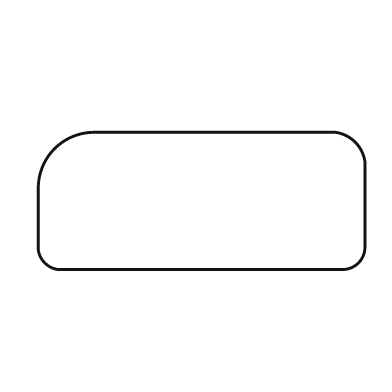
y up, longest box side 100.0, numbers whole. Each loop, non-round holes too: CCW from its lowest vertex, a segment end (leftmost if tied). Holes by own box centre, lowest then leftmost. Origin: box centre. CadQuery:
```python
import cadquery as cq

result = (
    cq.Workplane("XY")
    .moveTo(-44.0, -21.0)
    .lineTo(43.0, -21.0)
    .threePointArc((48.0, -19.0), (50.0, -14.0))
    .lineTo(50.0, 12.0)
    .threePointArc((47.0, 18.0), (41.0, 21.0))
    .lineTo(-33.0, 21.0)
    .threePointArc((-45.0, 16.0), (-50.0, 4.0))
    .lineTo(-50.0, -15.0)
    .threePointArc((-48.0, -19.0), (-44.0, -21.0))
    .close()
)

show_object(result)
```